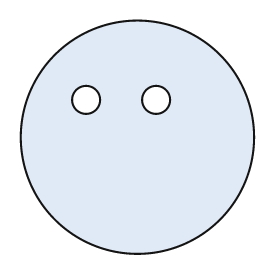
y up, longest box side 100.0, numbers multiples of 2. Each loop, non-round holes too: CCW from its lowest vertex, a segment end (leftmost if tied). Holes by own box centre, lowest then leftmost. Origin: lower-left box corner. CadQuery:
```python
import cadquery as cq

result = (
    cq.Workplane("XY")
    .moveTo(50.0, 50.0)
    .circle(50.0)
    .moveTo(28.0, 66.0)
    .circle(6.0)
    .moveTo(58.0, 66.0)
    .circle(6.0)
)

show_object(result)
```